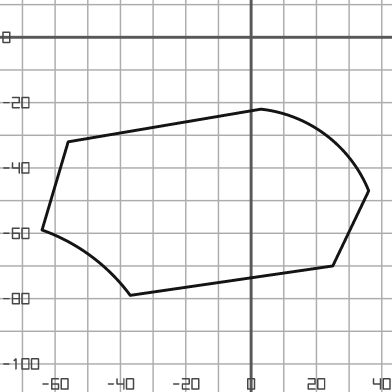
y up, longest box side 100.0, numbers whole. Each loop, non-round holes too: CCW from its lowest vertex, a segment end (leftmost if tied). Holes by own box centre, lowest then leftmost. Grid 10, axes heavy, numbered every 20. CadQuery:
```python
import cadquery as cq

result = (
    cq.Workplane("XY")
    .moveTo(-37.0, -79.0)
    .lineTo(25.0, -70.0)
    .lineTo(36.0, -47.0)
    .threePointArc((23.0, -30.0), (3.0, -22.0))
    .lineTo(-56.0, -32.0)
    .lineTo(-64.0, -59.0)
    .threePointArc((-49.0, -67.0), (-37.0, -79.0))
    .close()
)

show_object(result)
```